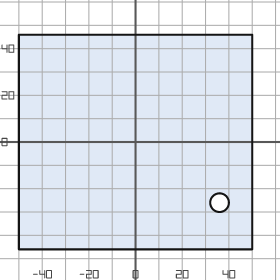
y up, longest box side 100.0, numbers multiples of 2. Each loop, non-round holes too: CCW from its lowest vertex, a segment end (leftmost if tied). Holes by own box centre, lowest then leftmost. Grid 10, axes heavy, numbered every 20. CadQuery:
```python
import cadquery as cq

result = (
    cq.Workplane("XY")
    .moveTo(-50.0, -46.0)
    .lineTo(50.0, -46.0)
    .lineTo(50.0, 46.0)
    .lineTo(-50.0, 46.0)
    .close()
    .moveTo(36.0, -26.0)
    .circle(4.0)
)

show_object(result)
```